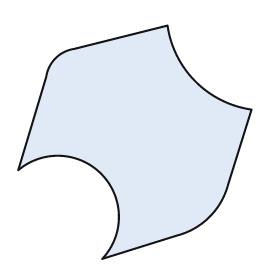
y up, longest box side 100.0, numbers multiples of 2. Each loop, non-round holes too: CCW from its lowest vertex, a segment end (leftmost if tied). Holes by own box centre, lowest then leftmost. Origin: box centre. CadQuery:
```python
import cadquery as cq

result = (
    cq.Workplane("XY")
    .moveTo(-14.0, -50.0)
    .lineTo(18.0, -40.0)
    .threePointArc((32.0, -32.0), (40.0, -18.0))
    .lineTo(50.0, 14.0)
    .threePointArc((26.0, 26.0), (14.0, 50.0))
    .lineTo(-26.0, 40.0)
    .threePointArc((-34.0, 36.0), (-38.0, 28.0))
    .lineTo(-50.0, -12.0)
    .threePointArc((-14.0, -14.0), (-14.0, -50.0))
    .close()
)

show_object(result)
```